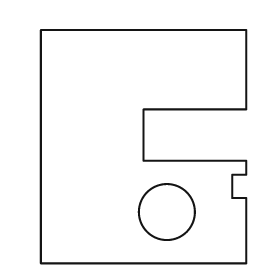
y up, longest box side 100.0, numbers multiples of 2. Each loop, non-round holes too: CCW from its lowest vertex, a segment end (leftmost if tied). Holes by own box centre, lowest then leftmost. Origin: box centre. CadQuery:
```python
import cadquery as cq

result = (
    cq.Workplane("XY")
    .moveTo(-44.0, -50.0)
    .lineTo(44.0, -50.0)
    .lineTo(44.0, -22.0)
    .lineTo(38.0, -22.0)
    .lineTo(38.0, -12.0)
    .lineTo(44.0, -12.0)
    .lineTo(44.0, -6.0)
    .lineTo(0.0, -6.0)
    .lineTo(0.0, 16.0)
    .lineTo(44.0, 16.0)
    .lineTo(44.0, 50.0)
    .lineTo(-44.0, 50.0)
    .close()
    .moveTo(10.0, -28.0)
    .circle(12.0)
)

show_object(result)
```